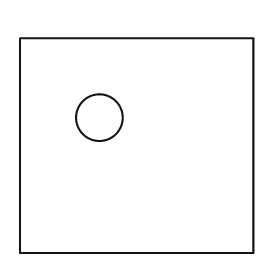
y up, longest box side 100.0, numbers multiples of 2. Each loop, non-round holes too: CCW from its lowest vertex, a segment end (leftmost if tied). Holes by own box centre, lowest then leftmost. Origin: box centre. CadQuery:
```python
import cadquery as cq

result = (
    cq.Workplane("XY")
    .moveTo(-50.0, -46.0)
    .lineTo(50.0, -46.0)
    .lineTo(50.0, 46.0)
    .lineTo(-50.0, 46.0)
    .close()
    .moveTo(-16.0, 12.0)
    .circle(10.0)
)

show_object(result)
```